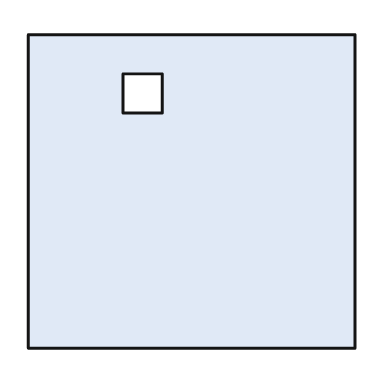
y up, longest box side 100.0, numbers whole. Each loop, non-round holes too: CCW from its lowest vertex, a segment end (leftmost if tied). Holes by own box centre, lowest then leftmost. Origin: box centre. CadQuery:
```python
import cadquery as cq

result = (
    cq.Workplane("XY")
    .moveTo(-50.0, -48.0)
    .lineTo(50.0, -48.0)
    .lineTo(50.0, 48.0)
    .lineTo(-50.0, 48.0)
    .close()
    .moveTo(-21.0, 24.0)
    .lineTo(-9.0, 24.0)
    .lineTo(-9.0, 36.0)
    .lineTo(-21.0, 36.0)
    .close()
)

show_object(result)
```